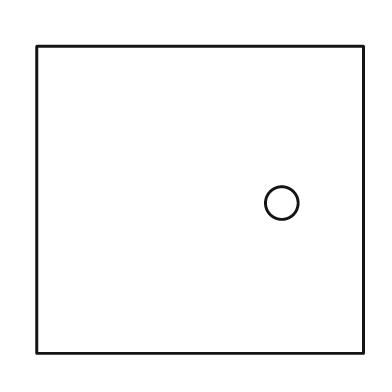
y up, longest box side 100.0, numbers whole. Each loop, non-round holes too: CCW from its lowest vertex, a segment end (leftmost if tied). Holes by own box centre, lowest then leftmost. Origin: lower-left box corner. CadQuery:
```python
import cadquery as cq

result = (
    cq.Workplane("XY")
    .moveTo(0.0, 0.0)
    .lineTo(100.0, 0.0)
    .lineTo(100.0, 94.0)
    .lineTo(0.0, 94.0)
    .close()
    .moveTo(75.0, 46.0)
    .circle(5.0)
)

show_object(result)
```